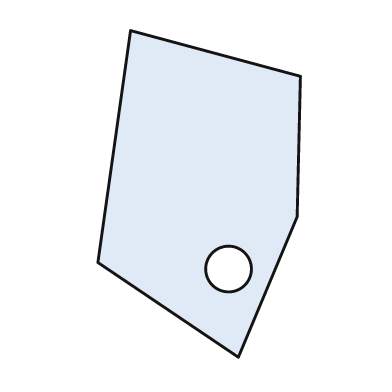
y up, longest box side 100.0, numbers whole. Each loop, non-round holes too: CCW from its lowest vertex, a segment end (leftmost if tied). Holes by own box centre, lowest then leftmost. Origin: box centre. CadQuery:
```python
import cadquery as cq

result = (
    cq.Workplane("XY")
    .moveTo(12.0, -50.0)
    .lineTo(30.0, -7.0)
    .lineTo(31.0, 36.0)
    .lineTo(-21.0, 50.0)
    .lineTo(-31.0, -21.0)
    .close()
    .moveTo(9.0, -23.0)
    .circle(7.0)
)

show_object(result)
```